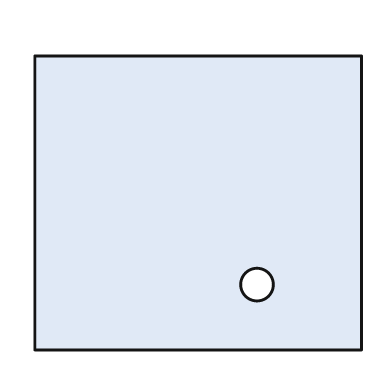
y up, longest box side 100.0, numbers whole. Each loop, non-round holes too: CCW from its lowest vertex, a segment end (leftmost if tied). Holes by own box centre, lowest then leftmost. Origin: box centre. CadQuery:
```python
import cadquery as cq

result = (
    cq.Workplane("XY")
    .moveTo(-50.0, -45.0)
    .lineTo(50.0, -45.0)
    .lineTo(50.0, 45.0)
    .lineTo(-50.0, 45.0)
    .close()
    .moveTo(18.0, -25.0)
    .circle(5.0)
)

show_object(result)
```